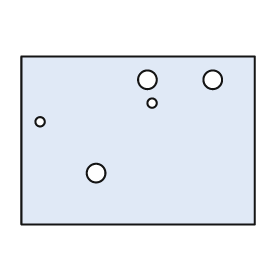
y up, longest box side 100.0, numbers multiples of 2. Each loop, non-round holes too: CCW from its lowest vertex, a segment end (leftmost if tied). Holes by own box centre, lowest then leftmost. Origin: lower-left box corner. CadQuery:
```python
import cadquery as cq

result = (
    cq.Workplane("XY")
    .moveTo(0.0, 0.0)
    .lineTo(100.0, 0.0)
    .lineTo(100.0, 72.0)
    .lineTo(0.0, 72.0)
    .close()
    .moveTo(32.0, 22.0)
    .circle(4.0)
    .moveTo(8.0, 44.0)
    .circle(2.0)
    .moveTo(56.0, 52.0)
    .circle(2.0)
    .moveTo(54.0, 62.0)
    .circle(4.0)
    .moveTo(82.0, 62.0)
    .circle(4.0)
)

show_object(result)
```